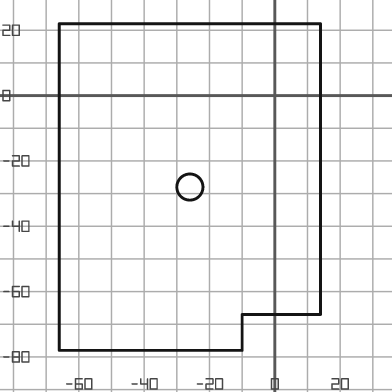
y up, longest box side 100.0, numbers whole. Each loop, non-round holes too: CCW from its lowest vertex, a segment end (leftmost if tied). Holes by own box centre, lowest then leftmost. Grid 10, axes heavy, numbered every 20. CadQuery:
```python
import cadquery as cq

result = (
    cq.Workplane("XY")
    .moveTo(-66.0, -78.0)
    .lineTo(-10.0, -78.0)
    .lineTo(-10.0, -67.0)
    .lineTo(14.0, -67.0)
    .lineTo(14.0, 22.0)
    .lineTo(-66.0, 22.0)
    .close()
    .moveTo(-26.0, -28.0)
    .circle(4.0)
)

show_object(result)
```